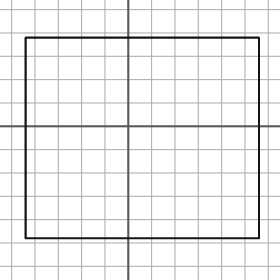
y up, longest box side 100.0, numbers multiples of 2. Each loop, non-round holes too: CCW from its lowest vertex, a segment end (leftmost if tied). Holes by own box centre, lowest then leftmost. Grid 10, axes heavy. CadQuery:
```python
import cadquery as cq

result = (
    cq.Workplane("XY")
    .moveTo(-44.0, -48.0)
    .lineTo(56.0, -48.0)
    .lineTo(56.0, 38.0)
    .lineTo(-44.0, 38.0)
    .close()
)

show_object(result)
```